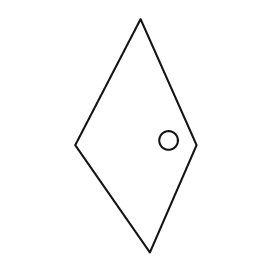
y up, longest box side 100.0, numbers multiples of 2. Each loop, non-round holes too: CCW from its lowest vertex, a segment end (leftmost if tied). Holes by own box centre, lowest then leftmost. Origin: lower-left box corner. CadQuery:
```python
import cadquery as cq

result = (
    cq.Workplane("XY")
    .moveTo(32.0, 0.0)
    .lineTo(52.0, 46.0)
    .lineTo(28.0, 100.0)
    .lineTo(0.0, 46.0)
    .close()
    .moveTo(40.0, 48.0)
    .circle(4.0)
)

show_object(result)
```